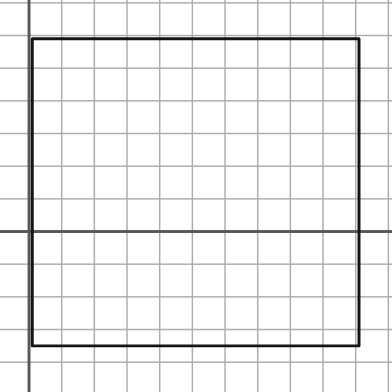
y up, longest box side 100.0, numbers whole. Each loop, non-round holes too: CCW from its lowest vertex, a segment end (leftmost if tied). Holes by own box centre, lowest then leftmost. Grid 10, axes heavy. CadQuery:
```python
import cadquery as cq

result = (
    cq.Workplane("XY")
    .moveTo(1.0, -35.0)
    .lineTo(101.0, -35.0)
    .lineTo(101.0, 59.0)
    .lineTo(1.0, 59.0)
    .close()
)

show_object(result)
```